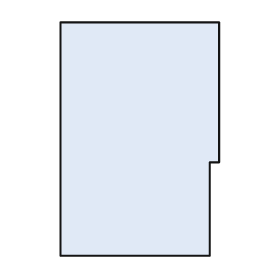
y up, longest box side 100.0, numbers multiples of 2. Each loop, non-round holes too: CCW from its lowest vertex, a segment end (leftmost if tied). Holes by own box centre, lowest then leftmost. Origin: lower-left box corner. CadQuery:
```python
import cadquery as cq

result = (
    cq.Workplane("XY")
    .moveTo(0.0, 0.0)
    .lineTo(64.0, 0.0)
    .lineTo(64.0, 40.0)
    .lineTo(68.0, 40.0)
    .lineTo(68.0, 100.0)
    .lineTo(0.0, 100.0)
    .close()
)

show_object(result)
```